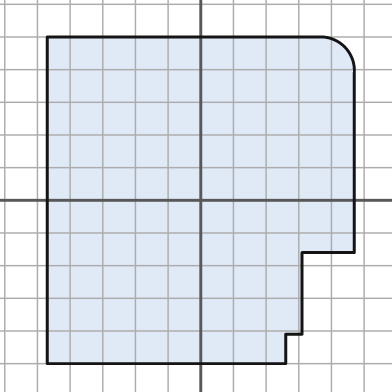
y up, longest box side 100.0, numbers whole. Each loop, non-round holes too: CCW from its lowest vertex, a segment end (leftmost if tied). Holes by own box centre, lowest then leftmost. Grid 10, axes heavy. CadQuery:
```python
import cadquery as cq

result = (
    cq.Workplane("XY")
    .moveTo(-47.0, -50.0)
    .lineTo(26.0, -50.0)
    .lineTo(26.0, -41.0)
    .lineTo(31.0, -41.0)
    .lineTo(31.0, -16.0)
    .lineTo(47.0, -16.0)
    .lineTo(47.0, 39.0)
    .threePointArc((44.0, 47.0), (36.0, 50.0))
    .lineTo(-47.0, 50.0)
    .close()
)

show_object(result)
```